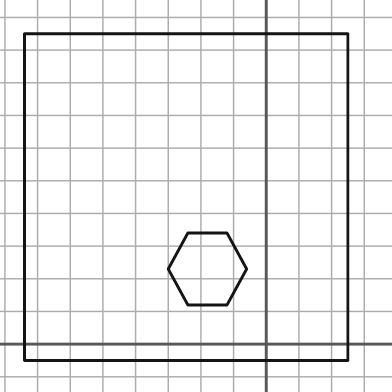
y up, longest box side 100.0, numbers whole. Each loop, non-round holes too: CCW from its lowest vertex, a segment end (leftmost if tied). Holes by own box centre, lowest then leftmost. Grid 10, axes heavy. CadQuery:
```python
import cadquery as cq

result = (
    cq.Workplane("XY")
    .moveTo(-74.0, -5.0)
    .lineTo(25.0, -5.0)
    .lineTo(25.0, 95.0)
    .lineTo(-74.0, 95.0)
    .close()
    .moveTo(-24.0, 12.0)
    .lineTo(-12.0, 12.0)
    .lineTo(-6.0, 23.0)
    .lineTo(-12.0, 34.0)
    .lineTo(-24.0, 34.0)
    .lineTo(-30.0, 23.0)
    .close()
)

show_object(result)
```